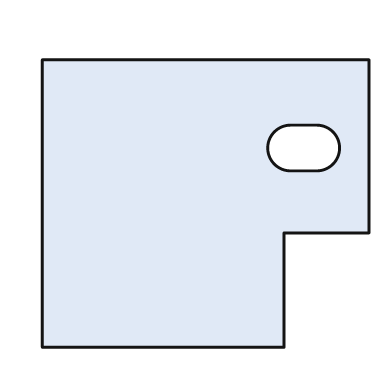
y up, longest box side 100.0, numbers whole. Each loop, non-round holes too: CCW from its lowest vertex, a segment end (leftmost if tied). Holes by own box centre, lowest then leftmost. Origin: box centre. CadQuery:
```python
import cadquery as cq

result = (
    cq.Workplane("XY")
    .moveTo(-50.0, -44.0)
    .lineTo(24.0, -44.0)
    .lineTo(24.0, -9.0)
    .lineTo(50.0, -9.0)
    .lineTo(50.0, 44.0)
    .lineTo(-50.0, 44.0)
    .close()
    .moveTo(26.0, 10.0)
    .lineTo(34.0, 10.0)
    .threePointArc((41.0, 17.0), (34.0, 24.0))
    .lineTo(26.0, 24.0)
    .threePointArc((19.0, 17.0), (26.0, 10.0))
    .close()
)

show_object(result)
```